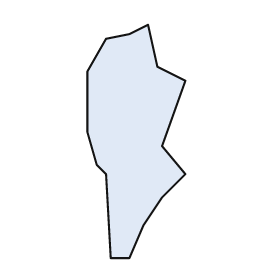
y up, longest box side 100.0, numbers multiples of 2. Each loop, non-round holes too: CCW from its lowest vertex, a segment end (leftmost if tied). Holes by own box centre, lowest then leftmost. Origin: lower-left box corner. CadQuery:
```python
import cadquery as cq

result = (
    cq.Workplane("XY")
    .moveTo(10.0, 0.0)
    .lineTo(18.0, 0.0)
    .lineTo(24.0, 14.0)
    .lineTo(32.0, 26.0)
    .lineTo(42.0, 36.0)
    .lineTo(32.0, 48.0)
    .lineTo(42.0, 76.0)
    .lineTo(30.0, 82.0)
    .lineTo(26.0, 100.0)
    .lineTo(18.0, 96.0)
    .lineTo(8.0, 94.0)
    .lineTo(0.0, 80.0)
    .lineTo(0.0, 54.0)
    .lineTo(4.0, 40.0)
    .lineTo(8.0, 36.0)
    .close()
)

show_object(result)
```